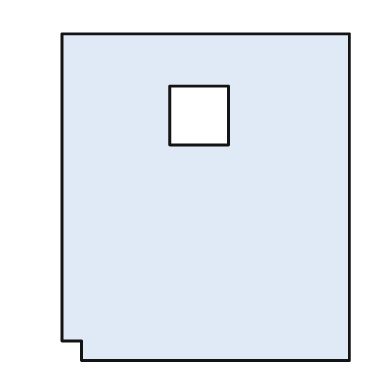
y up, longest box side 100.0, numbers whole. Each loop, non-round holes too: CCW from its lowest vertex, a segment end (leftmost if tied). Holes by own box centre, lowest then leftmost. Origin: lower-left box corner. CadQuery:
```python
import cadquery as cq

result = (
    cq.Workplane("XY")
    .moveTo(6.0, 0.0)
    .lineTo(88.0, 0.0)
    .lineTo(88.0, 100.0)
    .lineTo(0.0, 100.0)
    .lineTo(0.0, 6.0)
    .lineTo(6.0, 6.0)
    .close()
    .moveTo(33.0, 66.0)
    .lineTo(51.0, 66.0)
    .lineTo(51.0, 84.0)
    .lineTo(33.0, 84.0)
    .close()
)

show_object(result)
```